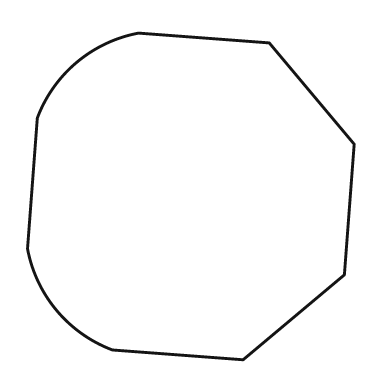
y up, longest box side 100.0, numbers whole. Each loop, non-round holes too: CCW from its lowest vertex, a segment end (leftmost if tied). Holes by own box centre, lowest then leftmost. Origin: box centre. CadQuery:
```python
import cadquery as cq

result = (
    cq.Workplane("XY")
    .moveTo(16.0, -50.0)
    .lineTo(47.0, -24.0)
    .lineTo(50.0, 16.0)
    .lineTo(24.0, 47.0)
    .lineTo(-16.0, 50.0)
    .threePointArc((-35.0, 41.0), (-47.0, 24.0))
    .lineTo(-50.0, -16.0)
    .threePointArc((-41.0, -35.0), (-24.0, -47.0))
    .close()
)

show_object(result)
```